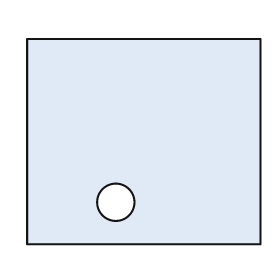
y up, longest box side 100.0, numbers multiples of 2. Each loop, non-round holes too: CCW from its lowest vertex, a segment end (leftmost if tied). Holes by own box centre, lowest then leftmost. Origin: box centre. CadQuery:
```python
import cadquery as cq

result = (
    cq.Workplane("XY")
    .moveTo(-50.0, -44.0)
    .lineTo(50.0, -44.0)
    .lineTo(50.0, 44.0)
    .lineTo(-50.0, 44.0)
    .close()
    .moveTo(-12.0, -26.0)
    .circle(8.0)
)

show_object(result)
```